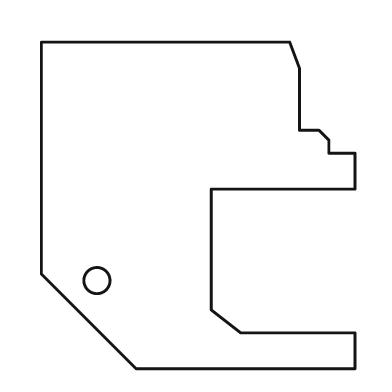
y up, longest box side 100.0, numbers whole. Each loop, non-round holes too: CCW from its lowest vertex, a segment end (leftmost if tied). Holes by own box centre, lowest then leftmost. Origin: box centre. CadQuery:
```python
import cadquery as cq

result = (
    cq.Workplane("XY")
    .moveTo(-19.0, -50.0)
    .lineTo(48.0, -50.0)
    .lineTo(48.0, -39.0)
    .lineTo(13.0, -39.0)
    .lineTo(4.0, -32.0)
    .lineTo(4.0, 5.0)
    .lineTo(48.0, 5.0)
    .lineTo(48.0, 16.0)
    .lineTo(40.0, 16.0)
    .lineTo(40.0, 20.0)
    .lineTo(37.0, 23.0)
    .lineTo(31.0, 23.0)
    .lineTo(31.0, 42.0)
    .lineTo(28.0, 50.0)
    .lineTo(-48.0, 50.0)
    .lineTo(-48.0, -21.0)
    .close()
    .moveTo(-31.0, -23.0)
    .circle(4.0)
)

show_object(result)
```